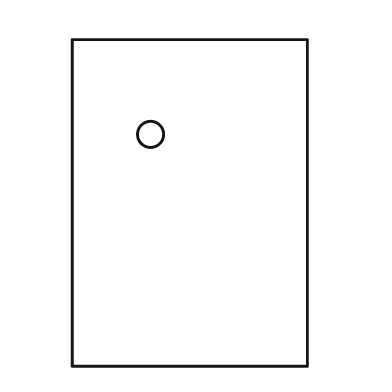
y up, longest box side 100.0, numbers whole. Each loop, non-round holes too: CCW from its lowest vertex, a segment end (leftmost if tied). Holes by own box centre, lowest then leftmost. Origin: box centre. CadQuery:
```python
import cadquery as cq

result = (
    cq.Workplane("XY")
    .moveTo(-36.0, -50.0)
    .lineTo(36.0, -50.0)
    .lineTo(36.0, 50.0)
    .lineTo(-36.0, 50.0)
    .close()
    .moveTo(-12.0, 21.0)
    .circle(4.0)
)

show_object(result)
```